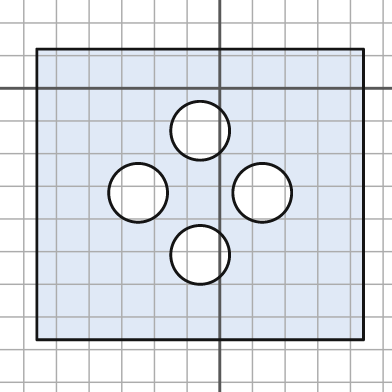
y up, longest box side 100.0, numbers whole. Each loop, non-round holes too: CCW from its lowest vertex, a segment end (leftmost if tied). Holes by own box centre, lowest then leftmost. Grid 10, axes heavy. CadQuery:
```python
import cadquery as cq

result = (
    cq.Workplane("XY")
    .moveTo(-56.0, -77.0)
    .lineTo(44.0, -77.0)
    .lineTo(44.0, 12.0)
    .lineTo(-56.0, 12.0)
    .close()
    .moveTo(-6.0, -51.0)
    .circle(9.0)
    .moveTo(-25.0, -32.0)
    .circle(9.0)
    .moveTo(13.0, -32.0)
    .circle(9.0)
    .moveTo(-6.0, -13.0)
    .circle(9.0)
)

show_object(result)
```